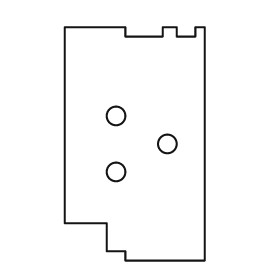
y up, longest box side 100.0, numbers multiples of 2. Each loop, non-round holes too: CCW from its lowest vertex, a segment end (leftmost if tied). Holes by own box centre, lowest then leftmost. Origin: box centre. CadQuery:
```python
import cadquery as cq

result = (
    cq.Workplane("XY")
    .moveTo(-4.0, -50.0)
    .lineTo(30.0, -50.0)
    .lineTo(30.0, 50.0)
    .lineTo(26.0, 50.0)
    .lineTo(26.0, 46.0)
    .lineTo(18.0, 46.0)
    .lineTo(18.0, 50.0)
    .lineTo(12.0, 50.0)
    .lineTo(12.0, 46.0)
    .lineTo(-4.0, 46.0)
    .lineTo(-4.0, 50.0)
    .lineTo(-30.0, 50.0)
    .lineTo(-30.0, -34.0)
    .lineTo(-12.0, -34.0)
    .lineTo(-12.0, -46.0)
    .lineTo(-4.0, -46.0)
    .close()
    .moveTo(-8.0, -12.0)
    .circle(4.0)
    .moveTo(14.0, 0.0)
    .circle(4.0)
    .moveTo(-8.0, 12.0)
    .circle(4.0)
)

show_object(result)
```